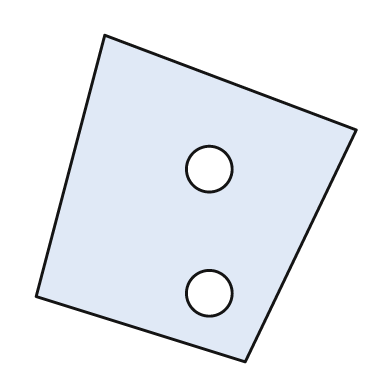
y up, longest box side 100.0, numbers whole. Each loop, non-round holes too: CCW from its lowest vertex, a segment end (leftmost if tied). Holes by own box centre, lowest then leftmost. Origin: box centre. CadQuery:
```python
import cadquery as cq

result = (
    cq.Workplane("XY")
    .moveTo(15.0, -50.0)
    .lineTo(49.0, 21.0)
    .lineTo(-28.0, 50.0)
    .lineTo(-49.0, -30.0)
    .close()
    .moveTo(4.0, -29.0)
    .circle(7.0)
    .moveTo(4.0, 9.0)
    .circle(7.0)
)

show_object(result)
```